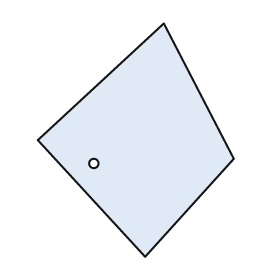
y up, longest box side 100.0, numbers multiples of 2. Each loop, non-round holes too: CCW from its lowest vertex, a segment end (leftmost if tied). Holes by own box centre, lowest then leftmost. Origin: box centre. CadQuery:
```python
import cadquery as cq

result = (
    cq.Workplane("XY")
    .moveTo(4.0, -50.0)
    .lineTo(42.0, -8.0)
    .lineTo(12.0, 50.0)
    .lineTo(-42.0, 0.0)
    .close()
    .moveTo(-18.0, -10.0)
    .circle(2.0)
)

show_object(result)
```